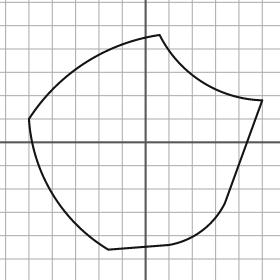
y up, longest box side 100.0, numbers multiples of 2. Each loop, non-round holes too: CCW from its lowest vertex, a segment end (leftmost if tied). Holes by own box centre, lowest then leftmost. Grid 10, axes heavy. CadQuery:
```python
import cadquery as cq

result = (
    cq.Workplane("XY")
    .moveTo(-16.0, -46.0)
    .lineTo(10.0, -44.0)
    .threePointArc((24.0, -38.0), (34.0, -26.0))
    .lineTo(50.0, 18.0)
    .threePointArc((24.0, 26.0), (6.0, 46.0))
    .threePointArc((-26.0, 34.0), (-50.0, 10.0))
    .threePointArc((-40.0, -22.0), (-16.0, -46.0))
    .close()
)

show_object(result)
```